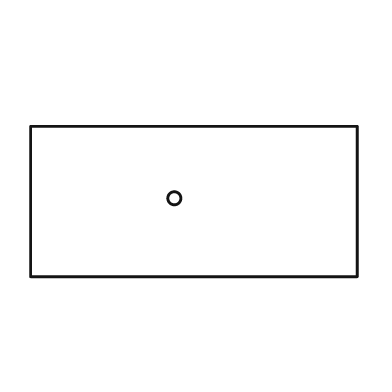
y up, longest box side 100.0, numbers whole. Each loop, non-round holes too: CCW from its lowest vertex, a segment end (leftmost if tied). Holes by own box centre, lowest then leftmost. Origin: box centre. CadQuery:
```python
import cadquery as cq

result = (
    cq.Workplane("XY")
    .moveTo(-50.0, -23.0)
    .lineTo(50.0, -23.0)
    .lineTo(50.0, 23.0)
    .lineTo(-50.0, 23.0)
    .close()
    .moveTo(-6.0, 1.0)
    .circle(2.0)
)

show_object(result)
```